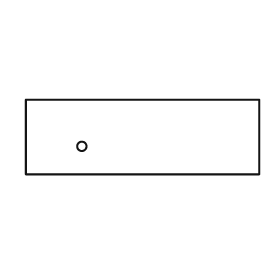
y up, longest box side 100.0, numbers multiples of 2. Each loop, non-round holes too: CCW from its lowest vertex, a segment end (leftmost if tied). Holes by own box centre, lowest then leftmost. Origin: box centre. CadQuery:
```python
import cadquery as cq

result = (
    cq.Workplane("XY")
    .moveTo(-50.0, -16.0)
    .lineTo(50.0, -16.0)
    .lineTo(50.0, 16.0)
    .lineTo(-50.0, 16.0)
    .close()
    .moveTo(-26.0, -4.0)
    .circle(2.0)
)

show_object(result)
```